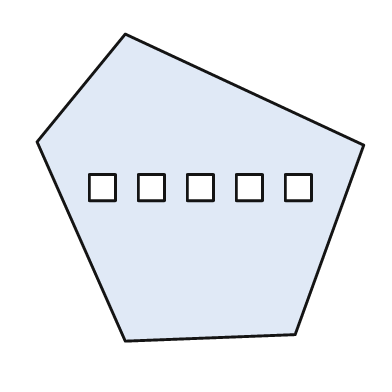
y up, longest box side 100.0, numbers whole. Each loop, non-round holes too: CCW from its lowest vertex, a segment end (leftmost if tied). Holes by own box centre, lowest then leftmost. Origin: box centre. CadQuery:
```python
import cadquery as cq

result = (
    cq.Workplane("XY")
    .moveTo(-23.0, -47.0)
    .lineTo(29.0, -45.0)
    .lineTo(50.0, 13.0)
    .lineTo(-23.0, 47.0)
    .lineTo(-50.0, 14.0)
    .close()
    .moveTo(-34.0, -4.0)
    .lineTo(-26.0, -4.0)
    .lineTo(-26.0, 4.0)
    .lineTo(-34.0, 4.0)
    .close()
    .moveTo(-19.0, -4.0)
    .lineTo(-11.0, -4.0)
    .lineTo(-11.0, 4.0)
    .lineTo(-19.0, 4.0)
    .close()
    .moveTo(-4.0, -4.0)
    .lineTo(4.0, -4.0)
    .lineTo(4.0, 4.0)
    .lineTo(-4.0, 4.0)
    .close()
    .moveTo(11.0, -4.0)
    .lineTo(19.0, -4.0)
    .lineTo(19.0, 4.0)
    .lineTo(11.0, 4.0)
    .close()
    .moveTo(26.0, -4.0)
    .lineTo(34.0, -4.0)
    .lineTo(34.0, 4.0)
    .lineTo(26.0, 4.0)
    .close()
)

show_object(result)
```